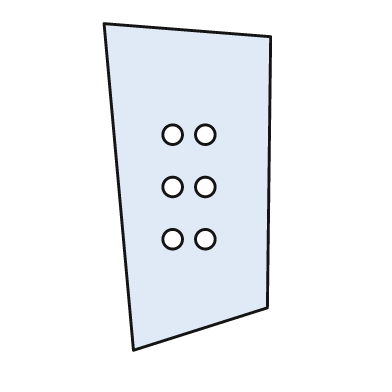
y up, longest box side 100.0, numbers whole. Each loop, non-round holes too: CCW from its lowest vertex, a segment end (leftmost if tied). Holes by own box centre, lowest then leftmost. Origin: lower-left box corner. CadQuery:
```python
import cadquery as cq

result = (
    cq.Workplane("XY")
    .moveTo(9.0, 0.0)
    .lineTo(50.0, 13.0)
    .lineTo(51.0, 96.0)
    .lineTo(0.0, 100.0)
    .close()
    .moveTo(21.0, 34.0)
    .circle(3.0)
    .moveTo(31.0, 34.0)
    .circle(3.0)
    .moveTo(21.0, 50.0)
    .circle(3.0)
    .moveTo(31.0, 50.0)
    .circle(3.0)
    .moveTo(21.0, 66.0)
    .circle(3.0)
    .moveTo(31.0, 66.0)
    .circle(3.0)
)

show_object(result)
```